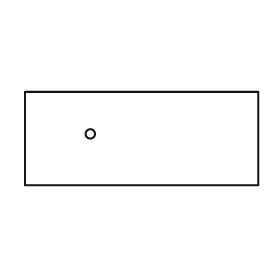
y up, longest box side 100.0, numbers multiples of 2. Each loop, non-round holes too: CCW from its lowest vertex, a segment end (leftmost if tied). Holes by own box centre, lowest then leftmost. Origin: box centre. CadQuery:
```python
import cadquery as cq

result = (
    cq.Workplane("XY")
    .moveTo(-50.0, -20.0)
    .lineTo(50.0, -20.0)
    .lineTo(50.0, 20.0)
    .lineTo(-50.0, 20.0)
    .close()
    .moveTo(-22.0, 2.0)
    .circle(2.0)
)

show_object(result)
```